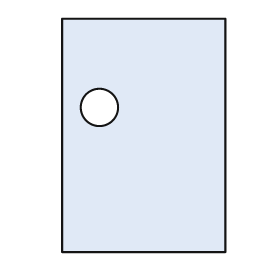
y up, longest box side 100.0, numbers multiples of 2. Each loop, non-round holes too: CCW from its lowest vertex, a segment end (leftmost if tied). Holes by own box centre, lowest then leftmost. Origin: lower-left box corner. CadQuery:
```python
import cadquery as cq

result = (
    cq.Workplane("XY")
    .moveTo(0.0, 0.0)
    .lineTo(70.0, 0.0)
    .lineTo(70.0, 100.0)
    .lineTo(0.0, 100.0)
    .close()
    .moveTo(16.0, 62.0)
    .circle(8.0)
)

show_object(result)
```